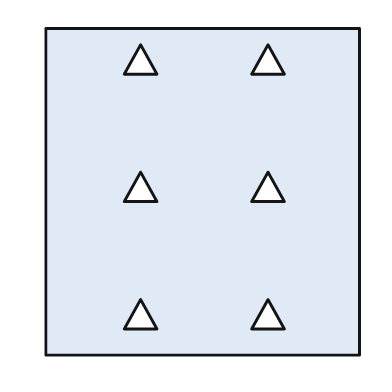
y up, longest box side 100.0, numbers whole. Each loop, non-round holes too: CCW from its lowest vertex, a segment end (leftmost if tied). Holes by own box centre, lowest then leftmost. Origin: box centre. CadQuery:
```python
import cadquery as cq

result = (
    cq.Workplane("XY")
    .moveTo(-48.0, -50.0)
    .lineTo(48.0, -50.0)
    .lineTo(48.0, 50.0)
    .lineTo(-48.0, 50.0)
    .close()
    .moveTo(-24.0, -42.0)
    .lineTo(-14.0, -42.0)
    .lineTo(-19.0, -33.0)
    .close()
    .moveTo(15.0, -42.0)
    .lineTo(25.0, -42.0)
    .lineTo(20.0, -33.0)
    .close()
    .moveTo(-24.0, -3.0)
    .lineTo(-14.0, -3.0)
    .lineTo(-19.0, 6.0)
    .close()
    .moveTo(15.0, -3.0)
    .lineTo(25.0, -3.0)
    .lineTo(20.0, 6.0)
    .close()
    .moveTo(-24.0, 36.0)
    .lineTo(-14.0, 36.0)
    .lineTo(-19.0, 45.0)
    .close()
    .moveTo(15.0, 36.0)
    .lineTo(25.0, 36.0)
    .lineTo(20.0, 45.0)
    .close()
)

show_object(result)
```